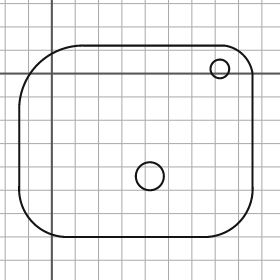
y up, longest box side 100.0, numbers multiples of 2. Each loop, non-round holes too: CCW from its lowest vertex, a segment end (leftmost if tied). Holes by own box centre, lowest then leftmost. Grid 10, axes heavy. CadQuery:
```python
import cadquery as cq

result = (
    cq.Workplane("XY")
    .moveTo(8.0, -70.0)
    .lineTo(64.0, -70.0)
    .threePointArc((80.0, -64.0), (86.0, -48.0))
    .lineTo(86.0, 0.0)
    .threePointArc((82.0, 8.0), (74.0, 12.0))
    .lineTo(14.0, 12.0)
    .threePointArc((-6.0, 4.0), (-14.0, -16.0))
    .lineTo(-14.0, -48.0)
    .threePointArc((-8.0, -64.0), (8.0, -70.0))
    .close()
    .moveTo(42.0, -44.0)
    .circle(6.0)
    .moveTo(72.0, 2.0)
    .circle(4.0)
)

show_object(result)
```